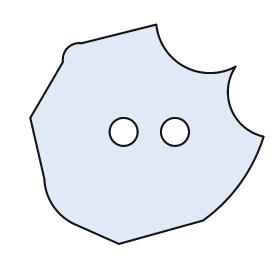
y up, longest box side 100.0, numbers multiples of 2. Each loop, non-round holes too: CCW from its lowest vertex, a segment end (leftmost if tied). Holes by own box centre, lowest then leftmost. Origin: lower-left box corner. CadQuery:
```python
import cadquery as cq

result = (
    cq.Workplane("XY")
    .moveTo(38.0, 0.0)
    .lineTo(74.0, 10.0)
    .threePointArc((90.0, 26.0), (100.0, 46.0))
    .threePointArc((86.0, 58.0), (88.0, 76.0))
    .threePointArc((66.0, 76.0), (54.0, 94.0))
    .lineTo(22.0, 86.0)
    .threePointArc((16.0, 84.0), (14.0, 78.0))
    .lineTo(0.0, 54.0)
    .lineTo(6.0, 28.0)
    .threePointArc((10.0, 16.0), (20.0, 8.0))
    .close()
    .moveTo(40.0, 48.0)
    .circle(6.0)
    .moveTo(62.0, 48.0)
    .circle(6.0)
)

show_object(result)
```